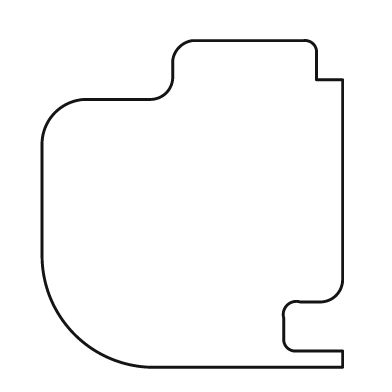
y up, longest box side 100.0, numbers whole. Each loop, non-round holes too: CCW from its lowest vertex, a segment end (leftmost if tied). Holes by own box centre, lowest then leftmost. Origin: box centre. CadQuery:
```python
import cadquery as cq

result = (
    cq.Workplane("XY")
    .moveTo(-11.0, -50.0)
    .lineTo(46.0, -50.0)
    .lineTo(46.0, -45.0)
    .lineTo(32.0, -45.0)
    .threePointArc((29.0, -44.0), (28.0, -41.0))
    .lineTo(28.0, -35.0)
    .threePointArc((29.0, -31.0), (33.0, -30.0))
    .lineTo(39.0, -30.0)
    .threePointArc((44.0, -28.0), (46.0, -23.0))
    .lineTo(46.0, 38.0)
    .lineTo(38.0, 38.0)
    .lineTo(38.0, 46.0)
    .threePointArc((37.0, 49.0), (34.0, 50.0))
    .lineTo(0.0, 50.0)
    .threePointArc((-4.0, 48.0), (-6.0, 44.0))
    .lineTo(-6.0, 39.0)
    .threePointArc((-8.0, 34.0), (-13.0, 32.0))
    .lineTo(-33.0, 32.0)
    .threePointArc((-42.0, 28.0), (-46.0, 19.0))
    .lineTo(-46.0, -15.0)
    .threePointArc((-36.0, -40.0), (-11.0, -50.0))
    .close()
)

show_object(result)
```